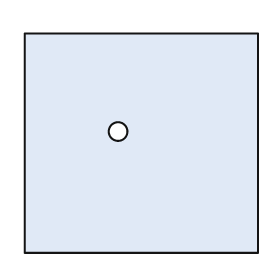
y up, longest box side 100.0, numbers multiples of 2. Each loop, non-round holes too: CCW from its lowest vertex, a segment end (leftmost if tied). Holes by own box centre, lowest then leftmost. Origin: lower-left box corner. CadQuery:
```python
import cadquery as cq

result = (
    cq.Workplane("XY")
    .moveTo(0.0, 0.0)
    .lineTo(100.0, 0.0)
    .lineTo(100.0, 94.0)
    .lineTo(0.0, 94.0)
    .close()
    .moveTo(40.0, 52.0)
    .circle(4.0)
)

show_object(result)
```